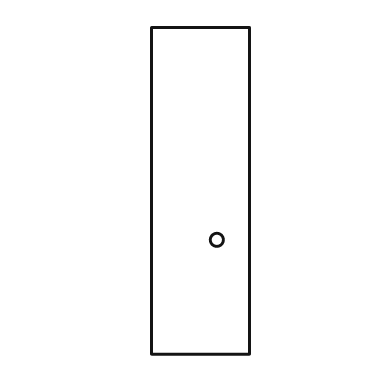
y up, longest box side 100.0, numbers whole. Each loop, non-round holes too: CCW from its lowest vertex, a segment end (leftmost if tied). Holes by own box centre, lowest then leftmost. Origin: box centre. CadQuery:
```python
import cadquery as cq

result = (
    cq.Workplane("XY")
    .moveTo(-15.0, -50.0)
    .lineTo(15.0, -50.0)
    .lineTo(15.0, 50.0)
    .lineTo(-15.0, 50.0)
    .close()
    .moveTo(5.0, -15.0)
    .circle(2.0)
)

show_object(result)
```